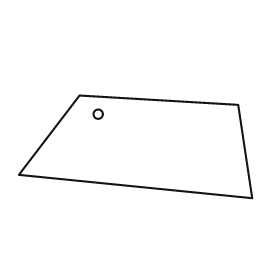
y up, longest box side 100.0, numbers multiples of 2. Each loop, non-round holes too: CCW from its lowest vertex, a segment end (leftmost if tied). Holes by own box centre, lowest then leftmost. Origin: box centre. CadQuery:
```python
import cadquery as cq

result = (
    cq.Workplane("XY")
    .moveTo(50.0, -22.0)
    .lineTo(44.0, 18.0)
    .lineTo(-24.0, 22.0)
    .lineTo(-50.0, -12.0)
    .close()
    .moveTo(-16.0, 14.0)
    .circle(2.0)
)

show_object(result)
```